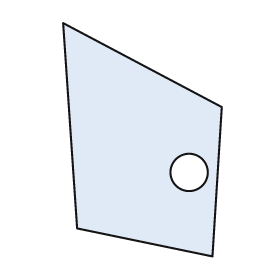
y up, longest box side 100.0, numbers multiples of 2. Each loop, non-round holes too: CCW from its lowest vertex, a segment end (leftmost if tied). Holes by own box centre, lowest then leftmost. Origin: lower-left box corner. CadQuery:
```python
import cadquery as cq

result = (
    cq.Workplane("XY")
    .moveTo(64.0, 0.0)
    .lineTo(68.0, 64.0)
    .lineTo(0.0, 100.0)
    .lineTo(6.0, 12.0)
    .close()
    .moveTo(54.0, 36.0)
    .circle(8.0)
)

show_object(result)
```